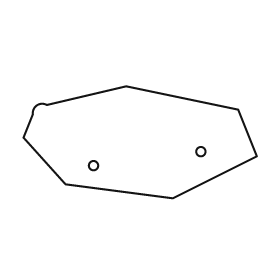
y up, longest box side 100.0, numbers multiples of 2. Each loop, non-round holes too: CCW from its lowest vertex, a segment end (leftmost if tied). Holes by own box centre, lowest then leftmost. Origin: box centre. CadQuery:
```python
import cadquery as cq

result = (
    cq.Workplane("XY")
    .moveTo(14.0, -24.0)
    .lineTo(50.0, -6.0)
    .lineTo(42.0, 14.0)
    .lineTo(-6.0, 24.0)
    .lineTo(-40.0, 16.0)
    .threePointArc((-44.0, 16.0), (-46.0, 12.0))
    .lineTo(-50.0, 2.0)
    .lineTo(-32.0, -18.0)
    .close()
    .moveTo(-20.0, -10.0)
    .circle(2.0)
    .moveTo(26.0, -4.0)
    .circle(2.0)
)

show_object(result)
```